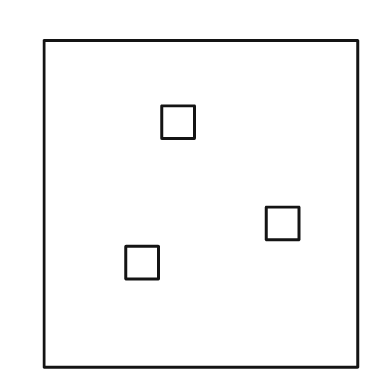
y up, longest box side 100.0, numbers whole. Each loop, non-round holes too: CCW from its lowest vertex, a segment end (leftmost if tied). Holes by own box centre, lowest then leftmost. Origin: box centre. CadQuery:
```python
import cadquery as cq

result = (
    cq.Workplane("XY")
    .moveTo(-48.0, -50.0)
    .lineTo(48.0, -50.0)
    .lineTo(48.0, 50.0)
    .lineTo(-48.0, 50.0)
    .close()
    .moveTo(-23.0, -23.0)
    .lineTo(-13.0, -23.0)
    .lineTo(-13.0, -13.0)
    .lineTo(-23.0, -13.0)
    .close()
    .moveTo(20.0, -11.0)
    .lineTo(30.0, -11.0)
    .lineTo(30.0, -1.0)
    .lineTo(20.0, -1.0)
    .close()
    .moveTo(-12.0, 20.0)
    .lineTo(-2.0, 20.0)
    .lineTo(-2.0, 30.0)
    .lineTo(-12.0, 30.0)
    .close()
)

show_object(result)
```